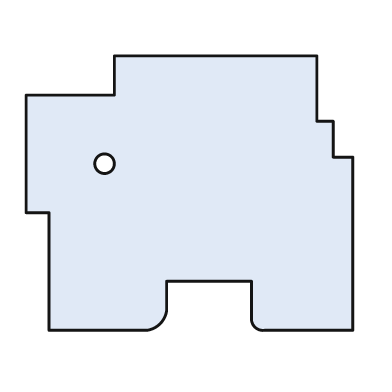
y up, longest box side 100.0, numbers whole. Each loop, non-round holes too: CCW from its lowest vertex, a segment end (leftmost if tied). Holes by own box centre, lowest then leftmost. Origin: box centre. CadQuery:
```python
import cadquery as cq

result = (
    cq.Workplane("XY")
    .moveTo(-43.0, -42.0)
    .lineTo(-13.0, -42.0)
    .threePointArc((-9.0, -40.0), (-7.0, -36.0))
    .lineTo(-7.0, -27.0)
    .lineTo(19.0, -27.0)
    .lineTo(19.0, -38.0)
    .threePointArc((20.0, -41.0), (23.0, -42.0))
    .lineTo(50.0, -42.0)
    .lineTo(50.0, 11.0)
    .lineTo(44.0, 11.0)
    .lineTo(44.0, 22.0)
    .lineTo(39.0, 22.0)
    .lineTo(39.0, 42.0)
    .lineTo(-23.0, 42.0)
    .lineTo(-23.0, 30.0)
    .lineTo(-50.0, 30.0)
    .lineTo(-50.0, -6.0)
    .lineTo(-43.0, -6.0)
    .close()
    .moveTo(-26.0, 9.0)
    .circle(3.0)
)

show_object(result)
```